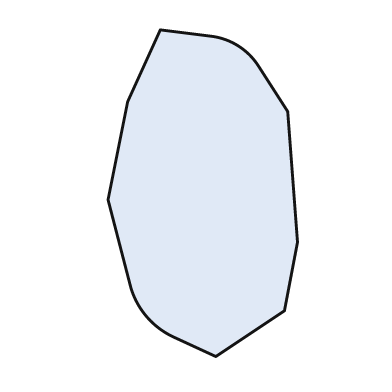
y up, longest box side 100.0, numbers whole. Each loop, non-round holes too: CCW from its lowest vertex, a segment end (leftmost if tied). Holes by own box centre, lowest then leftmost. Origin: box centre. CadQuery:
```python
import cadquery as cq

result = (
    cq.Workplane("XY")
    .moveTo(4.0, -50.0)
    .lineTo(25.0, -36.0)
    .lineTo(29.0, -15.0)
    .lineTo(26.0, 25.0)
    .lineTo(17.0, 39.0)
    .threePointArc((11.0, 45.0), (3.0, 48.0))
    .lineTo(-13.0, 50.0)
    .lineTo(-23.0, 28.0)
    .lineTo(-29.0, -2.0)
    .lineTo(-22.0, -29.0)
    .threePointArc((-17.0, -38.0), (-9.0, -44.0))
    .close()
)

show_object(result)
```